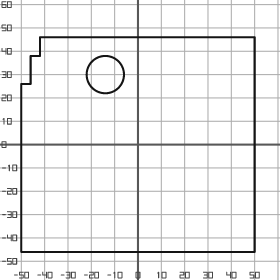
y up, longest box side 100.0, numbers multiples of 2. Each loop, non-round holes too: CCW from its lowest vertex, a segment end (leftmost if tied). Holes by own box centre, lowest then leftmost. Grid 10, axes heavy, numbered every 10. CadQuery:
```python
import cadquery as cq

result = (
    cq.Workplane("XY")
    .moveTo(-50.0, -46.0)
    .lineTo(50.0, -46.0)
    .lineTo(50.0, 46.0)
    .lineTo(-42.0, 46.0)
    .lineTo(-42.0, 38.0)
    .lineTo(-46.0, 38.0)
    .lineTo(-46.0, 26.0)
    .lineTo(-50.0, 26.0)
    .close()
    .moveTo(-14.0, 30.0)
    .circle(8.0)
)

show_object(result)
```